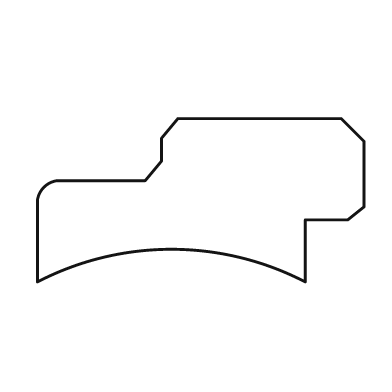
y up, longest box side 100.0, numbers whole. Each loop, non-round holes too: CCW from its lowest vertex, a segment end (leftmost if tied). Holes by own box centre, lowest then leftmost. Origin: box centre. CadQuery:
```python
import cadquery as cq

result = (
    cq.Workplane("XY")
    .moveTo(-50.0, -25.0)
    .threePointArc((-9.0, -15.0), (32.0, -25.0))
    .lineTo(32.0, -6.0)
    .lineTo(45.0, -6.0)
    .lineTo(50.0, -2.0)
    .lineTo(50.0, 18.0)
    .lineTo(43.0, 25.0)
    .lineTo(-7.0, 25.0)
    .lineTo(-12.0, 19.0)
    .lineTo(-12.0, 12.0)
    .lineTo(-17.0, 6.0)
    .lineTo(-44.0, 6.0)
    .threePointArc((-48.0, 4.0), (-50.0, 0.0))
    .close()
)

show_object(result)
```